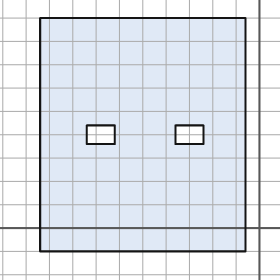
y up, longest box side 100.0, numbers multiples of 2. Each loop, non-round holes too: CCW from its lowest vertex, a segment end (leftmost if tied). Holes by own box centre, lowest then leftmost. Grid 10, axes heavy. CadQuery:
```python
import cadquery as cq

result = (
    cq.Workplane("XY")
    .moveTo(-94.0, -10.0)
    .lineTo(-6.0, -10.0)
    .lineTo(-6.0, 90.0)
    .lineTo(-94.0, 90.0)
    .close()
    .moveTo(-74.0, 36.0)
    .lineTo(-62.0, 36.0)
    .lineTo(-62.0, 44.0)
    .lineTo(-74.0, 44.0)
    .close()
    .moveTo(-36.0, 36.0)
    .lineTo(-24.0, 36.0)
    .lineTo(-24.0, 44.0)
    .lineTo(-36.0, 44.0)
    .close()
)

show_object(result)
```